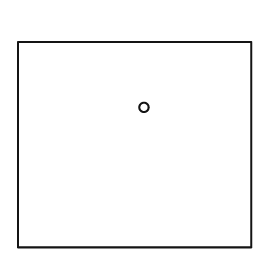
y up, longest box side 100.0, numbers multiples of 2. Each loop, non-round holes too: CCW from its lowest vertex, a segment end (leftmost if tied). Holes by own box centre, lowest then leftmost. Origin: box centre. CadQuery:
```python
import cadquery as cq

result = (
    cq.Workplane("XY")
    .moveTo(-50.0, -44.0)
    .lineTo(50.0, -44.0)
    .lineTo(50.0, 44.0)
    .lineTo(-50.0, 44.0)
    .close()
    .moveTo(4.0, 16.0)
    .circle(2.0)
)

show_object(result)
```